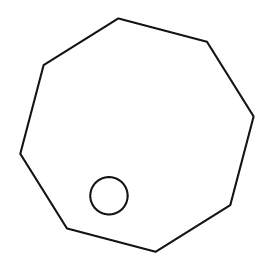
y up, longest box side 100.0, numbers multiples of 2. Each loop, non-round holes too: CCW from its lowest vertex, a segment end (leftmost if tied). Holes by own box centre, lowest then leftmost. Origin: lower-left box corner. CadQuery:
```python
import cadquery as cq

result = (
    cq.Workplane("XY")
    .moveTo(58.0, 0.0)
    .lineTo(90.0, 20.0)
    .lineTo(100.0, 58.0)
    .lineTo(80.0, 90.0)
    .lineTo(42.0, 100.0)
    .lineTo(10.0, 80.0)
    .lineTo(0.0, 42.0)
    .lineTo(20.0, 10.0)
    .close()
    .moveTo(38.0, 24.0)
    .circle(8.0)
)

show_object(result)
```